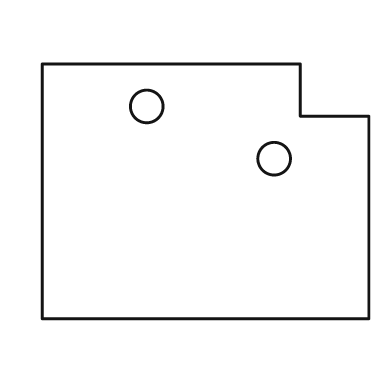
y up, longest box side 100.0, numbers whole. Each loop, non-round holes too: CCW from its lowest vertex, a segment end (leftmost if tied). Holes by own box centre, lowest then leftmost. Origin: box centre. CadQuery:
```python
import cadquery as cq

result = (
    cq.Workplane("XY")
    .moveTo(-50.0, -39.0)
    .lineTo(50.0, -39.0)
    .lineTo(50.0, 23.0)
    .lineTo(29.0, 23.0)
    .lineTo(29.0, 39.0)
    .lineTo(-50.0, 39.0)
    .close()
    .moveTo(21.0, 10.0)
    .circle(5.0)
    .moveTo(-18.0, 26.0)
    .circle(5.0)
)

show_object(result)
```